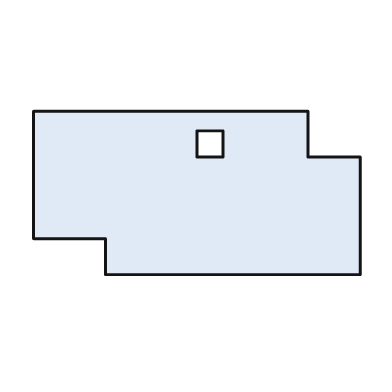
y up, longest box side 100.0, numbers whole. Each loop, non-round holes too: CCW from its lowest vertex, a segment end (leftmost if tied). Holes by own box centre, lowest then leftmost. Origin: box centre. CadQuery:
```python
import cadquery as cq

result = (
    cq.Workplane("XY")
    .moveTo(-28.0, -25.0)
    .lineTo(50.0, -25.0)
    .lineTo(50.0, 11.0)
    .lineTo(34.0, 11.0)
    .lineTo(34.0, 25.0)
    .lineTo(-50.0, 25.0)
    .lineTo(-50.0, -14.0)
    .lineTo(-28.0, -14.0)
    .close()
    .moveTo(0.0, 11.0)
    .lineTo(8.0, 11.0)
    .lineTo(8.0, 19.0)
    .lineTo(0.0, 19.0)
    .close()
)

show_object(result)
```